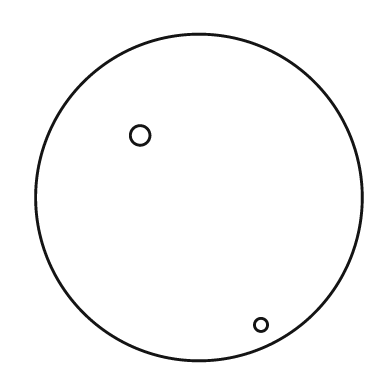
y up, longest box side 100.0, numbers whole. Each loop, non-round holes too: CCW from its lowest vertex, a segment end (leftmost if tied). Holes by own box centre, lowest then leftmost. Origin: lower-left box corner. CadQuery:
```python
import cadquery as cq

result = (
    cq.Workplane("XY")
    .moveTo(50.0, 50.0)
    .circle(50.0)
    .moveTo(69.0, 11.0)
    .circle(2.0)
    .moveTo(32.0, 69.0)
    .circle(3.0)
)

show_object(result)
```